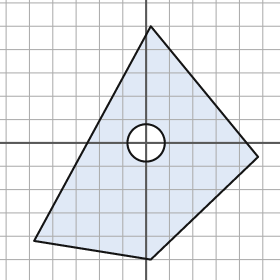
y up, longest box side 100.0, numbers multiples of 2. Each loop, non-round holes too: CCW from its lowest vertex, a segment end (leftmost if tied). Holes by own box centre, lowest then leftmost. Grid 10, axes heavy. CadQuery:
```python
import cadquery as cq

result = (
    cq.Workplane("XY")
    .moveTo(2.0, -50.0)
    .lineTo(48.0, -6.0)
    .lineTo(2.0, 50.0)
    .lineTo(-48.0, -42.0)
    .close()
    .moveTo(0.0, 0.0)
    .circle(8.0)
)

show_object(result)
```